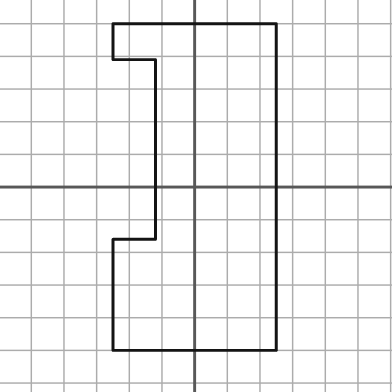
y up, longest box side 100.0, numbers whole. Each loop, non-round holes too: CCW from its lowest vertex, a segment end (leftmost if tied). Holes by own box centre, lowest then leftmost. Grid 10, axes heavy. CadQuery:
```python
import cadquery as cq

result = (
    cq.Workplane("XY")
    .moveTo(-25.0, -50.0)
    .lineTo(25.0, -50.0)
    .lineTo(25.0, 50.0)
    .lineTo(-25.0, 50.0)
    .lineTo(-25.0, 39.0)
    .lineTo(-12.0, 39.0)
    .lineTo(-12.0, -16.0)
    .lineTo(-25.0, -16.0)
    .close()
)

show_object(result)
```